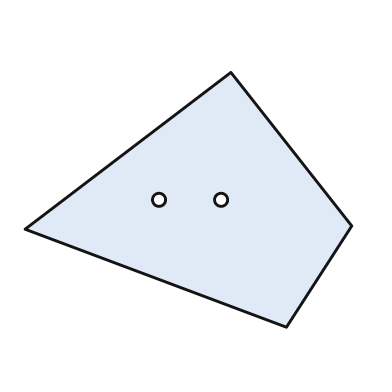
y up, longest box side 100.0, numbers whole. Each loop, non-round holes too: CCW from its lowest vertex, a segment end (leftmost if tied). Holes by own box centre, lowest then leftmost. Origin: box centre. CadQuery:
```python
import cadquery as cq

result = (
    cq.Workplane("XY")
    .moveTo(30.0, -39.0)
    .lineTo(50.0, -8.0)
    .lineTo(13.0, 39.0)
    .lineTo(-50.0, -9.0)
    .close()
    .moveTo(-9.0, 0.0)
    .circle(2.0)
    .moveTo(10.0, 0.0)
    .circle(2.0)
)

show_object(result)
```